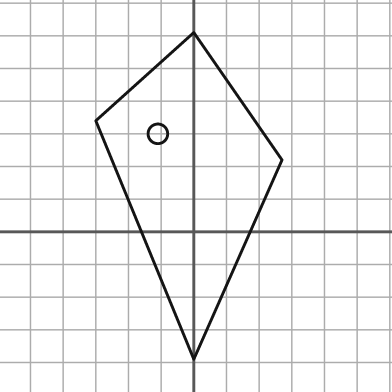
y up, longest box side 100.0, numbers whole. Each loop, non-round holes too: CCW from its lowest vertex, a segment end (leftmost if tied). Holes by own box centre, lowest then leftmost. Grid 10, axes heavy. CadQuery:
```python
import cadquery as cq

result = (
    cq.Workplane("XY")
    .moveTo(0.0, -39.0)
    .lineTo(27.0, 22.0)
    .lineTo(0.0, 61.0)
    .lineTo(-30.0, 34.0)
    .close()
    .moveTo(-11.0, 30.0)
    .circle(3.0)
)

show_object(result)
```